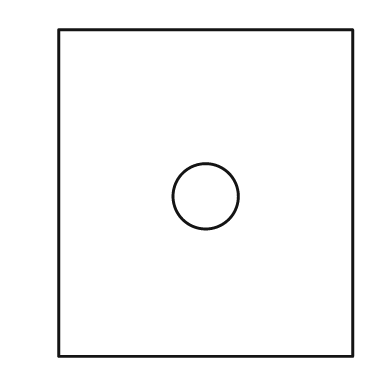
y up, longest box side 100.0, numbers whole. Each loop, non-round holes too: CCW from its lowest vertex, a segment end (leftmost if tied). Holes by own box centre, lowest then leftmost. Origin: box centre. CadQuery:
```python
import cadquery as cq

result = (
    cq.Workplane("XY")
    .moveTo(-45.0, -50.0)
    .lineTo(45.0, -50.0)
    .lineTo(45.0, 50.0)
    .lineTo(-45.0, 50.0)
    .close()
    .moveTo(0.0, -1.0)
    .circle(10.0)
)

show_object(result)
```